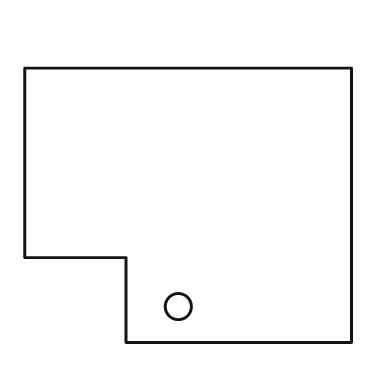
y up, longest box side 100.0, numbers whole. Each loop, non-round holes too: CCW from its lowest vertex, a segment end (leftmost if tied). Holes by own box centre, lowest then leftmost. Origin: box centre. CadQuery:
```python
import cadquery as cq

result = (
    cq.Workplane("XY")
    .moveTo(-19.0, -42.0)
    .lineTo(50.0, -42.0)
    .lineTo(50.0, 42.0)
    .lineTo(-50.0, 42.0)
    .lineTo(-50.0, -16.0)
    .lineTo(-19.0, -16.0)
    .close()
    .moveTo(-3.0, -31.0)
    .circle(4.0)
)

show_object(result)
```